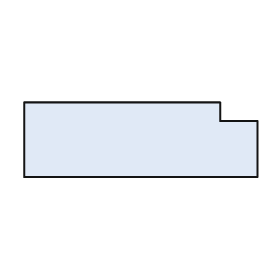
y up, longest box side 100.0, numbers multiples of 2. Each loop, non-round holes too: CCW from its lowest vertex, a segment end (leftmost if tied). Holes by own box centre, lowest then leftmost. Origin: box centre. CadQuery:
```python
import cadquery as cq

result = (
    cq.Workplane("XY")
    .moveTo(-50.0, -16.0)
    .lineTo(50.0, -16.0)
    .lineTo(50.0, 8.0)
    .lineTo(34.0, 8.0)
    .lineTo(34.0, 16.0)
    .lineTo(-50.0, 16.0)
    .close()
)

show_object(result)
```